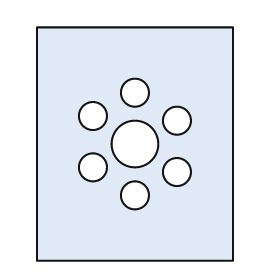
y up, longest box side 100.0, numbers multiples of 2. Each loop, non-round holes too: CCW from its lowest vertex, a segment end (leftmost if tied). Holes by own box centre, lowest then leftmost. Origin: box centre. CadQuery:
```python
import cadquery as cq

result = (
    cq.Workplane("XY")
    .moveTo(-42.0, -50.0)
    .lineTo(42.0, -50.0)
    .lineTo(42.0, 50.0)
    .lineTo(-42.0, 50.0)
    .close()
    .moveTo(0.0, -22.0)
    .circle(6.0)
    .moveTo(18.0, -12.0)
    .circle(6.0)
    .moveTo(-18.0, -10.0)
    .circle(6.0)
    .moveTo(0.0, 0.0)
    .circle(10.0)
    .moveTo(18.0, 10.0)
    .circle(6.0)
    .moveTo(-18.0, 12.0)
    .circle(6.0)
    .moveTo(0.0, 22.0)
    .circle(6.0)
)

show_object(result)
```